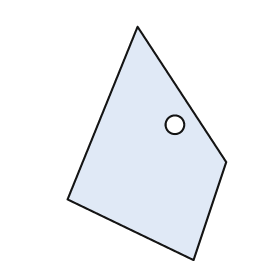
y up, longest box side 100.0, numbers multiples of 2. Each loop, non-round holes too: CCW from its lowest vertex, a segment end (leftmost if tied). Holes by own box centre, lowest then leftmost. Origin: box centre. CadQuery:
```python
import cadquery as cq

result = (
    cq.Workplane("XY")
    .moveTo(20.0, -50.0)
    .lineTo(34.0, -8.0)
    .lineTo(-4.0, 50.0)
    .lineTo(-34.0, -24.0)
    .close()
    .moveTo(12.0, 8.0)
    .circle(4.0)
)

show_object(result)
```